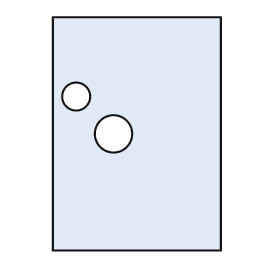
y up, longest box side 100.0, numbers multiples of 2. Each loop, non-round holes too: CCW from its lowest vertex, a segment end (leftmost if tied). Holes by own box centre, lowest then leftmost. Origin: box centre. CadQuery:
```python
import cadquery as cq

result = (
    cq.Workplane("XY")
    .moveTo(-36.0, -50.0)
    .lineTo(36.0, -50.0)
    .lineTo(36.0, 50.0)
    .lineTo(-36.0, 50.0)
    .close()
    .moveTo(-10.0, 0.0)
    .circle(8.0)
    .moveTo(-26.0, 16.0)
    .circle(6.0)
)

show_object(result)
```